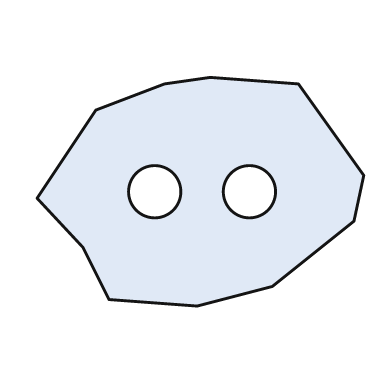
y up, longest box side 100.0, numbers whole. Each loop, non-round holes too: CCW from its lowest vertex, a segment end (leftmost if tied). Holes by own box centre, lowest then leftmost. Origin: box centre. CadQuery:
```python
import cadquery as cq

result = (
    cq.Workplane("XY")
    .moveTo(-1.0, -35.0)
    .lineTo(22.0, -29.0)
    .lineTo(47.0, -9.0)
    .lineTo(50.0, 5.0)
    .lineTo(30.0, 33.0)
    .lineTo(3.0, 35.0)
    .lineTo(-11.0, 33.0)
    .lineTo(-32.0, 25.0)
    .lineTo(-50.0, -2.0)
    .lineTo(-36.0, -17.0)
    .lineTo(-28.0, -33.0)
    .close()
    .moveTo(-14.0, 0.0)
    .circle(8.0)
    .moveTo(15.0, 0.0)
    .circle(8.0)
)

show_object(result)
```